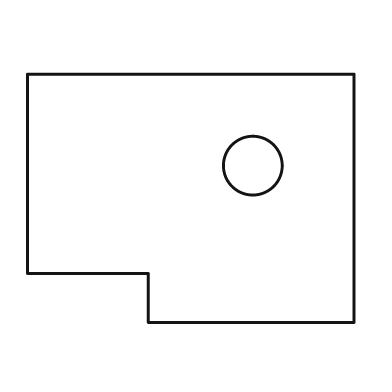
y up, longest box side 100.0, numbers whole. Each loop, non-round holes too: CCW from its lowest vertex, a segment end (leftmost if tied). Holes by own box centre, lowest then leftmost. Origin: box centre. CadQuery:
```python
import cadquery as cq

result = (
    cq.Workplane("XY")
    .moveTo(-13.0, -38.0)
    .lineTo(50.0, -38.0)
    .lineTo(50.0, 38.0)
    .lineTo(-50.0, 38.0)
    .lineTo(-50.0, -23.0)
    .lineTo(-13.0, -23.0)
    .close()
    .moveTo(19.0, 10.0)
    .circle(9.0)
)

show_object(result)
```